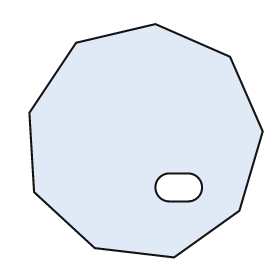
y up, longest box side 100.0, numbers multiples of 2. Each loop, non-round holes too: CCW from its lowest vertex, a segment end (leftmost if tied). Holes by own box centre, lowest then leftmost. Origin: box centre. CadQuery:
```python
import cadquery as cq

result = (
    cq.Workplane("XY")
    .moveTo(12.0, -50.0)
    .lineTo(40.0, -30.0)
    .lineTo(50.0, 4.0)
    .lineTo(36.0, 36.0)
    .lineTo(4.0, 50.0)
    .lineTo(-30.0, 42.0)
    .lineTo(-50.0, 12.0)
    .lineTo(-48.0, -22.0)
    .lineTo(-22.0, -46.0)
    .close()
    .moveTo(10.0, -26.0)
    .lineTo(18.0, -26.0)
    .threePointArc((24.0, -20.0), (18.0, -14.0))
    .lineTo(10.0, -14.0)
    .threePointArc((4.0, -20.0), (10.0, -26.0))
    .close()
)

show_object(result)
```